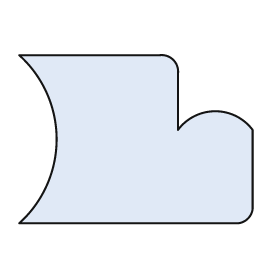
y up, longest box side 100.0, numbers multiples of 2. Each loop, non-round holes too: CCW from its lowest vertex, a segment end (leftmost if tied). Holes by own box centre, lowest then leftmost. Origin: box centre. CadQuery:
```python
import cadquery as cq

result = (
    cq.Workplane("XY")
    .moveTo(-50.0, -36.0)
    .lineTo(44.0, -36.0)
    .threePointArc((48.0, -34.0), (50.0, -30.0))
    .lineTo(50.0, 4.0)
    .threePointArc((34.0, 12.0), (18.0, 4.0))
    .lineTo(18.0, 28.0)
    .threePointArc((16.0, 34.0), (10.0, 36.0))
    .lineTo(-50.0, 36.0)
    .threePointArc((-34.0, 0.0), (-50.0, -36.0))
    .close()
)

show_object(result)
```